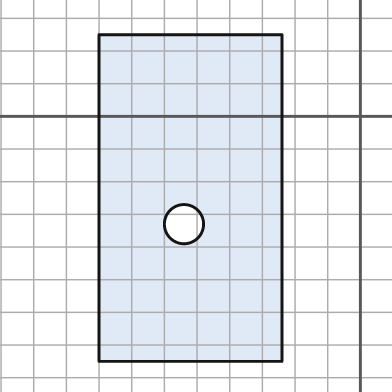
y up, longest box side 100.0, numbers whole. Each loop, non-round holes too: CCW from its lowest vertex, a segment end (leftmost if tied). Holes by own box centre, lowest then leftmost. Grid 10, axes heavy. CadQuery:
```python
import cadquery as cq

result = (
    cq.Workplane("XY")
    .moveTo(-80.0, -75.0)
    .lineTo(-24.0, -75.0)
    .lineTo(-24.0, 25.0)
    .lineTo(-80.0, 25.0)
    .close()
    .moveTo(-54.0, -33.0)
    .circle(6.0)
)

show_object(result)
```